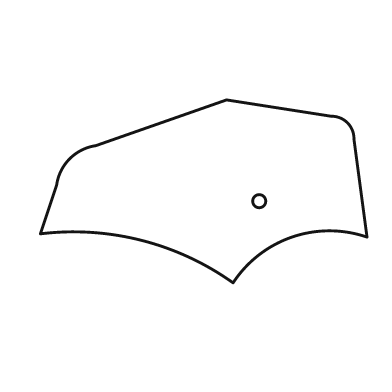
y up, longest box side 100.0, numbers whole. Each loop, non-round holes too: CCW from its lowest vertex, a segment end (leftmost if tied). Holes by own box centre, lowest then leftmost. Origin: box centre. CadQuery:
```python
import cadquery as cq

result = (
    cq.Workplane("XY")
    .moveTo(9.0, -28.0)
    .threePointArc((27.0, -14.0), (50.0, -14.0))
    .lineTo(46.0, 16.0)
    .threePointArc((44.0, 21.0), (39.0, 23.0))
    .lineTo(7.0, 28.0)
    .lineTo(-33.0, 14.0)
    .threePointArc((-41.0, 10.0), (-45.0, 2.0))
    .lineTo(-50.0, -13.0)
    .threePointArc((-19.0, -15.0), (9.0, -28.0))
    .close()
    .moveTo(17.0, -3.0)
    .circle(2.0)
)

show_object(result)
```